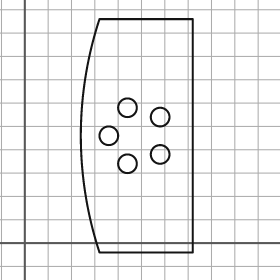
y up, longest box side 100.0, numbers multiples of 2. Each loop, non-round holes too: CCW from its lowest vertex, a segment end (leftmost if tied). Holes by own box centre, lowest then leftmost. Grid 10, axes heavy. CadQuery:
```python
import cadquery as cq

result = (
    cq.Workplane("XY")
    .moveTo(32.0, -4.0)
    .lineTo(72.0, -4.0)
    .lineTo(72.0, 96.0)
    .lineTo(32.0, 96.0)
    .threePointArc((24.0, 46.0), (32.0, -4.0))
    .close()
    .moveTo(44.0, 34.0)
    .circle(4.0)
    .moveTo(58.0, 38.0)
    .circle(4.0)
    .moveTo(36.0, 46.0)
    .circle(4.0)
    .moveTo(58.0, 54.0)
    .circle(4.0)
    .moveTo(44.0, 58.0)
    .circle(4.0)
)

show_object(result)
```